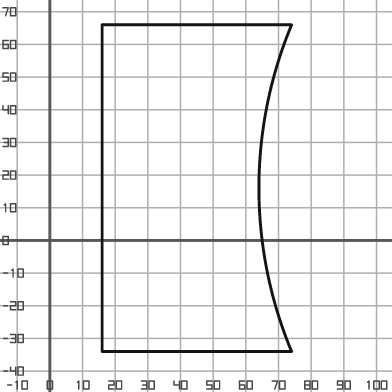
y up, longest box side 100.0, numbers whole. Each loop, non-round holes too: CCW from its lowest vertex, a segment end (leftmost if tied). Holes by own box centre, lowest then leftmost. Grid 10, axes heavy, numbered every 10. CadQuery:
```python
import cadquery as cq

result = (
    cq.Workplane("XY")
    .moveTo(16.0, -34.0)
    .lineTo(74.0, -34.0)
    .threePointArc((64.0, 16.0), (74.0, 66.0))
    .lineTo(16.0, 66.0)
    .close()
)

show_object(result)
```